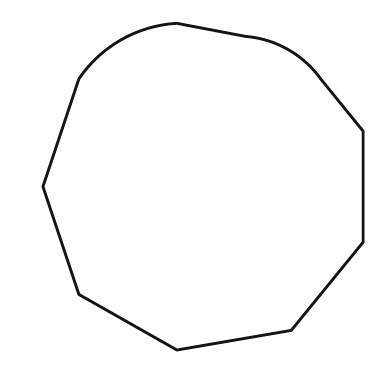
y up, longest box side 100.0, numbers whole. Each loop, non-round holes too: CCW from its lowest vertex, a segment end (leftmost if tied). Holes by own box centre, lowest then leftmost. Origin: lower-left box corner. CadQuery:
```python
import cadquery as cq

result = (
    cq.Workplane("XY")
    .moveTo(41.0, 0.0)
    .lineTo(76.0, 6.0)
    .lineTo(98.0, 33.0)
    .lineTo(98.0, 67.0)
    .lineTo(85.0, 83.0)
    .threePointArc((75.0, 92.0), (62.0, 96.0))
    .lineTo(41.0, 100.0)
    .threePointArc((24.0, 95.0), (11.0, 83.0))
    .lineTo(0.0, 50.0)
    .lineTo(11.0, 17.0)
    .close()
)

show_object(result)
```